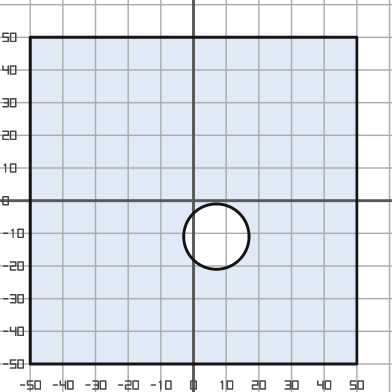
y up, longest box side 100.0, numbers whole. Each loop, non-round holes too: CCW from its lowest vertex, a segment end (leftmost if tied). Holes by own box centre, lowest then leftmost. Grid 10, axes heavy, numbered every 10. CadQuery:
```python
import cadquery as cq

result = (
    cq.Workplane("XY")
    .moveTo(-50.0, -50.0)
    .lineTo(50.0, -50.0)
    .lineTo(50.0, 50.0)
    .lineTo(-50.0, 50.0)
    .close()
    .moveTo(7.0, -11.0)
    .circle(10.0)
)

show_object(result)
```